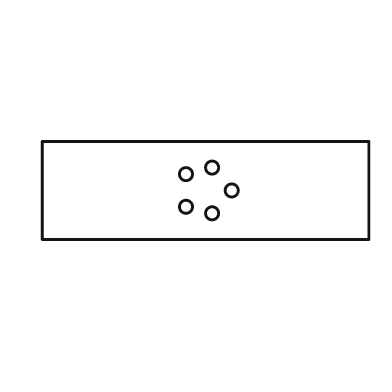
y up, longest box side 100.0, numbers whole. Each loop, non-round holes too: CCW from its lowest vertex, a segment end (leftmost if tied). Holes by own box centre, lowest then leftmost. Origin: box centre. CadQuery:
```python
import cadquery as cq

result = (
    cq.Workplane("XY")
    .moveTo(-50.0, -15.0)
    .lineTo(50.0, -15.0)
    .lineTo(50.0, 15.0)
    .lineTo(-50.0, 15.0)
    .close()
    .moveTo(2.0, -7.0)
    .circle(2.0)
    .moveTo(-6.0, -5.0)
    .circle(2.0)
    .moveTo(8.0, 0.0)
    .circle(2.0)
    .moveTo(-6.0, 5.0)
    .circle(2.0)
    .moveTo(2.0, 7.0)
    .circle(2.0)
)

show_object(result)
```